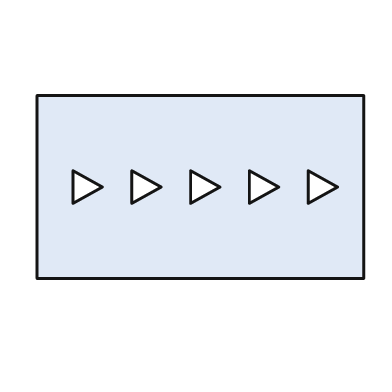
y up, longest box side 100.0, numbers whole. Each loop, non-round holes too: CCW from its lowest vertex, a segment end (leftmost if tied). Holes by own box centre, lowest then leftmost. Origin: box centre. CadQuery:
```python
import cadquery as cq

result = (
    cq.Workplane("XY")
    .moveTo(-50.0, -28.0)
    .lineTo(50.0, -28.0)
    .lineTo(50.0, 28.0)
    .lineTo(-50.0, 28.0)
    .close()
    .moveTo(-39.0, -5.0)
    .lineTo(-30.0, 0.0)
    .lineTo(-39.0, 5.0)
    .close()
    .moveTo(-21.0, -5.0)
    .lineTo(-12.0, 0.0)
    .lineTo(-21.0, 5.0)
    .close()
    .moveTo(-3.0, -5.0)
    .lineTo(6.0, 0.0)
    .lineTo(-3.0, 5.0)
    .close()
    .moveTo(15.0, -5.0)
    .lineTo(24.0, 0.0)
    .lineTo(15.0, 5.0)
    .close()
    .moveTo(33.0, -5.0)
    .lineTo(42.0, 0.0)
    .lineTo(33.0, 5.0)
    .close()
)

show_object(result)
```